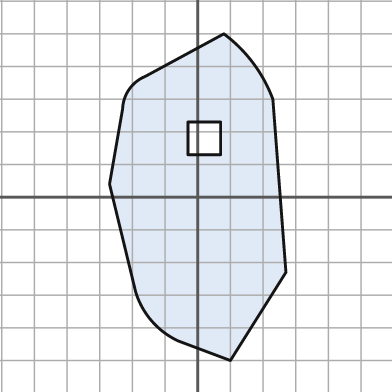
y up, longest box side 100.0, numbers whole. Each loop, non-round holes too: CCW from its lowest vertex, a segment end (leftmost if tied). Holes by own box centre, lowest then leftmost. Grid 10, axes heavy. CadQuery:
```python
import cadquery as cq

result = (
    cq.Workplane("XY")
    .moveTo(10.0, -50.0)
    .lineTo(27.0, -23.0)
    .lineTo(23.0, 30.0)
    .threePointArc((17.0, 41.0), (8.0, 50.0))
    .lineTo(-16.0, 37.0)
    .threePointArc((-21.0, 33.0), (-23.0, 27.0))
    .lineTo(-27.0, 4.0)
    .lineTo(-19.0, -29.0)
    .threePointArc((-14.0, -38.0), (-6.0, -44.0))
    .close()
    .moveTo(-3.0, 13.0)
    .lineTo(7.0, 13.0)
    .lineTo(7.0, 23.0)
    .lineTo(-3.0, 23.0)
    .close()
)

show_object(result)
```